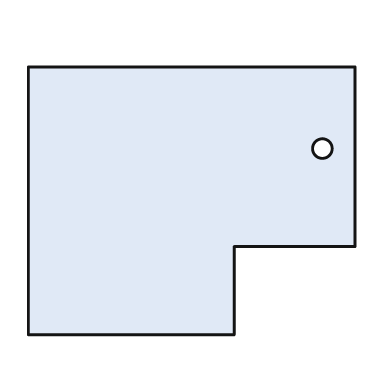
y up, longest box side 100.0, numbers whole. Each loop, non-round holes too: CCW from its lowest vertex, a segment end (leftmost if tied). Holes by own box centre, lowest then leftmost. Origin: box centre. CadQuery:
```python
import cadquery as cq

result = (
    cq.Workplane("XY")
    .moveTo(-50.0, -41.0)
    .lineTo(13.0, -41.0)
    .lineTo(13.0, -14.0)
    .lineTo(50.0, -14.0)
    .lineTo(50.0, 41.0)
    .lineTo(-50.0, 41.0)
    .close()
    .moveTo(40.0, 16.0)
    .circle(3.0)
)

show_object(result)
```